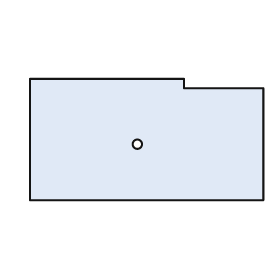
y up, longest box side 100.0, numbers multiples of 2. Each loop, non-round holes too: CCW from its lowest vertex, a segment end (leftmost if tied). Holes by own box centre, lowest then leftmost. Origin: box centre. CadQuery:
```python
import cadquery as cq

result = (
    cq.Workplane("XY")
    .moveTo(-50.0, -26.0)
    .lineTo(50.0, -26.0)
    .lineTo(50.0, 22.0)
    .lineTo(16.0, 22.0)
    .lineTo(16.0, 26.0)
    .lineTo(-50.0, 26.0)
    .close()
    .moveTo(-4.0, -2.0)
    .circle(2.0)
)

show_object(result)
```